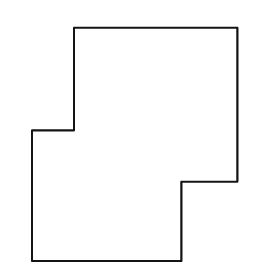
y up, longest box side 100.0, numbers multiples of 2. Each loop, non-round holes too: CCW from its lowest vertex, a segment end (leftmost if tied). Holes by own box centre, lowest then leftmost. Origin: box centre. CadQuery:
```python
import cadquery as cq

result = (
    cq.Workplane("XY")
    .moveTo(-44.0, -50.0)
    .lineTo(20.0, -50.0)
    .lineTo(20.0, -16.0)
    .lineTo(44.0, -16.0)
    .lineTo(44.0, 50.0)
    .lineTo(-26.0, 50.0)
    .lineTo(-26.0, 6.0)
    .lineTo(-44.0, 6.0)
    .close()
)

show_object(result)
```